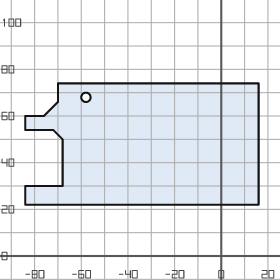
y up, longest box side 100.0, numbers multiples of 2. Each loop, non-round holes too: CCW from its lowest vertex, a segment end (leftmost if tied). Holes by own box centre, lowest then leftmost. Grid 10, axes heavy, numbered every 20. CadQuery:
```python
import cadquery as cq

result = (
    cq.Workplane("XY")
    .moveTo(-84.0, 22.0)
    .lineTo(16.0, 22.0)
    .lineTo(16.0, 74.0)
    .lineTo(-70.0, 74.0)
    .lineTo(-70.0, 66.0)
    .lineTo(-76.0, 60.0)
    .lineTo(-84.0, 60.0)
    .lineTo(-84.0, 54.0)
    .lineTo(-72.0, 54.0)
    .lineTo(-68.0, 50.0)
    .lineTo(-68.0, 30.0)
    .lineTo(-84.0, 30.0)
    .close()
    .moveTo(-58.0, 68.0)
    .circle(2.0)
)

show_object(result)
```